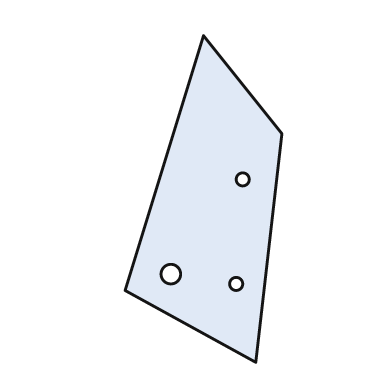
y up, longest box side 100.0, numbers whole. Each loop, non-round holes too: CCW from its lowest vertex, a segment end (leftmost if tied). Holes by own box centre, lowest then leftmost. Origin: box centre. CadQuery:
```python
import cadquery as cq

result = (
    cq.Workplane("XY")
    .moveTo(16.0, -50.0)
    .lineTo(24.0, 20.0)
    .lineTo(0.0, 50.0)
    .lineTo(-24.0, -28.0)
    .close()
    .moveTo(10.0, -26.0)
    .circle(2.0)
    .moveTo(-10.0, -23.0)
    .circle(3.0)
    .moveTo(12.0, 6.0)
    .circle(2.0)
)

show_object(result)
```